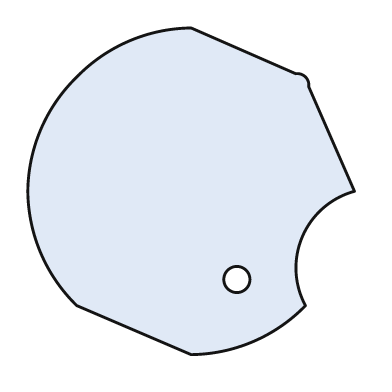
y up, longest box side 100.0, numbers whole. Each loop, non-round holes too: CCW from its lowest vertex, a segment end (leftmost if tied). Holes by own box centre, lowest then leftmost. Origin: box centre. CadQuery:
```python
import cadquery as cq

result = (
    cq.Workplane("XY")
    .moveTo(0.0, -50.0)
    .threePointArc((19.0, -46.0), (35.0, -35.0))
    .threePointArc((34.0, -14.0), (50.0, 0.0))
    .lineTo(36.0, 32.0)
    .threePointArc((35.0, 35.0), (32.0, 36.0))
    .lineTo(0.0, 50.0)
    .threePointArc((-19.0, 46.0), (-35.0, 35.0))
    .threePointArc((-46.0, 19.0), (-50.0, 0.0))
    .threePointArc((-46.0, -19.0), (-35.0, -35.0))
    .close()
    .moveTo(14.0, -27.0)
    .circle(4.0)
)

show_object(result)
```